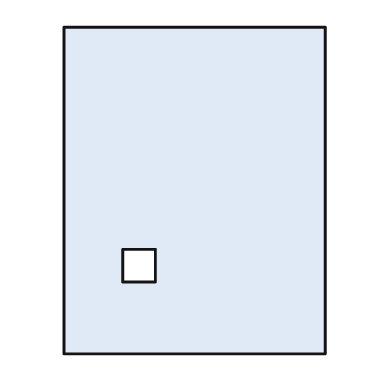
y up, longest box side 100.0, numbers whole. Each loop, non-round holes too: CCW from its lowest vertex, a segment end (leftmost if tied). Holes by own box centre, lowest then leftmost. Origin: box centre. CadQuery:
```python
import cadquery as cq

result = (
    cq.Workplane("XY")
    .moveTo(-40.0, -50.0)
    .lineTo(40.0, -50.0)
    .lineTo(40.0, 50.0)
    .lineTo(-40.0, 50.0)
    .close()
    .moveTo(-22.0, -28.0)
    .lineTo(-12.0, -28.0)
    .lineTo(-12.0, -18.0)
    .lineTo(-22.0, -18.0)
    .close()
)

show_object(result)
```